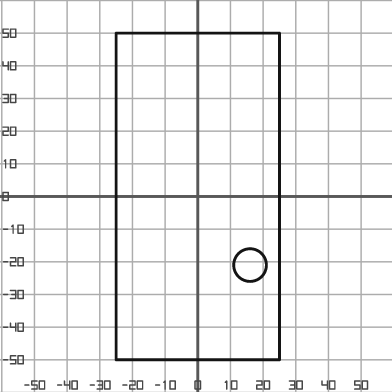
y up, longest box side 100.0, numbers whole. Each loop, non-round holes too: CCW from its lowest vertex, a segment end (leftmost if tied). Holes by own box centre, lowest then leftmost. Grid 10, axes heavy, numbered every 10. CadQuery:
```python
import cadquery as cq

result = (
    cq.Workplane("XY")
    .moveTo(-25.0, -50.0)
    .lineTo(25.0, -50.0)
    .lineTo(25.0, 50.0)
    .lineTo(-25.0, 50.0)
    .close()
    .moveTo(16.0, -21.0)
    .circle(5.0)
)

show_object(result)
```